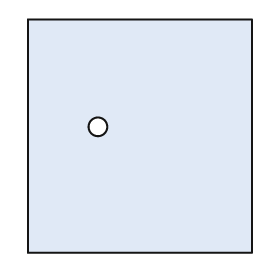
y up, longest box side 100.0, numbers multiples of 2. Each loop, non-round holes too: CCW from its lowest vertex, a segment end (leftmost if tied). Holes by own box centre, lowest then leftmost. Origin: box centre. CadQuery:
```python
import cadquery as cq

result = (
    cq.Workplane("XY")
    .moveTo(-48.0, -50.0)
    .lineTo(48.0, -50.0)
    .lineTo(48.0, 50.0)
    .lineTo(-48.0, 50.0)
    .close()
    .moveTo(-18.0, 4.0)
    .circle(4.0)
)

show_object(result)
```